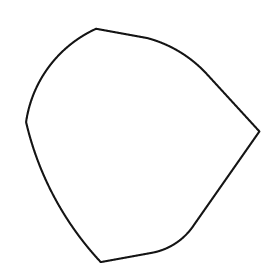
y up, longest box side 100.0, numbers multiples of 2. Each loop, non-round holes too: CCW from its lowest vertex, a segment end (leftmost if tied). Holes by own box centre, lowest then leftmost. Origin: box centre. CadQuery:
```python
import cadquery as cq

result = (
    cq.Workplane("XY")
    .moveTo(-18.0, -50.0)
    .lineTo(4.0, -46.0)
    .threePointArc((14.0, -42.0), (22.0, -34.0))
    .lineTo(50.0, 6.0)
    .lineTo(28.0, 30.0)
    .threePointArc((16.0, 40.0), (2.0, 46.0))
    .lineTo(-20.0, 50.0)
    .threePointArc((-40.0, 34.0), (-50.0, 10.0))
    .threePointArc((-38.0, -22.0), (-18.0, -50.0))
    .close()
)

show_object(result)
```